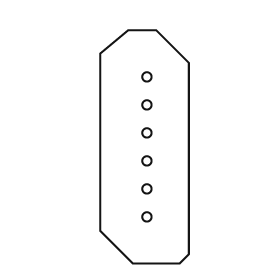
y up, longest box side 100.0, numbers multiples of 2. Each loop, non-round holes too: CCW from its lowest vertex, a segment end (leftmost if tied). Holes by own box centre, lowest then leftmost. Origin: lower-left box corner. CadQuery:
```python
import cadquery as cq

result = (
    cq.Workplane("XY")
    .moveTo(14.0, 0.0)
    .lineTo(34.0, 0.0)
    .lineTo(38.0, 4.0)
    .lineTo(38.0, 86.0)
    .lineTo(24.0, 100.0)
    .lineTo(12.0, 100.0)
    .lineTo(0.0, 90.0)
    .lineTo(0.0, 14.0)
    .close()
    .moveTo(20.0, 20.0)
    .circle(2.0)
    .moveTo(20.0, 32.0)
    .circle(2.0)
    .moveTo(20.0, 44.0)
    .circle(2.0)
    .moveTo(20.0, 56.0)
    .circle(2.0)
    .moveTo(20.0, 68.0)
    .circle(2.0)
    .moveTo(20.0, 80.0)
    .circle(2.0)
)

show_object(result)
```